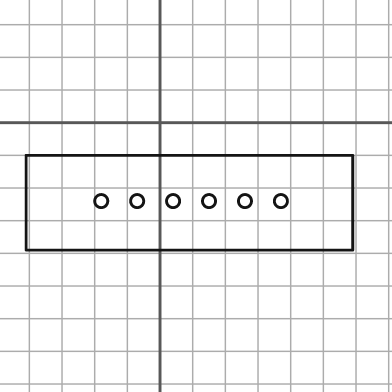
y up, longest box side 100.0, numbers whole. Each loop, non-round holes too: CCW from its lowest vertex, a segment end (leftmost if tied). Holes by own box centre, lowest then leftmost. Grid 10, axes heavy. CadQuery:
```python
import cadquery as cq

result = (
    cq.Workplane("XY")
    .moveTo(-41.0, -39.0)
    .lineTo(59.0, -39.0)
    .lineTo(59.0, -10.0)
    .lineTo(-41.0, -10.0)
    .close()
    .moveTo(-18.0, -24.0)
    .circle(2.0)
    .moveTo(-7.0, -24.0)
    .circle(2.0)
    .moveTo(4.0, -24.0)
    .circle(2.0)
    .moveTo(15.0, -24.0)
    .circle(2.0)
    .moveTo(26.0, -24.0)
    .circle(2.0)
    .moveTo(37.0, -24.0)
    .circle(2.0)
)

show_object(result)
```